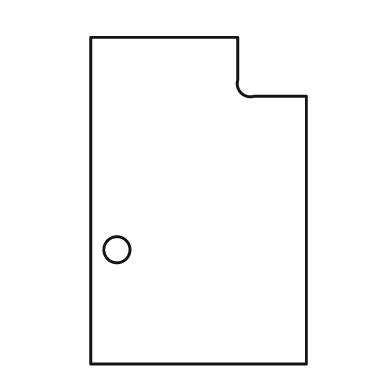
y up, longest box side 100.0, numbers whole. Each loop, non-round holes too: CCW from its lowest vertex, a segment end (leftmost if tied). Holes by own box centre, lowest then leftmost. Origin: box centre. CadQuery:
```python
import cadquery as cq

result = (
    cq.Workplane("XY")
    .moveTo(-33.0, -50.0)
    .lineTo(33.0, -50.0)
    .lineTo(33.0, 32.0)
    .lineTo(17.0, 32.0)
    .threePointArc((13.0, 33.0), (12.0, 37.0))
    .lineTo(12.0, 50.0)
    .lineTo(-33.0, 50.0)
    .close()
    .moveTo(-25.0, -15.0)
    .circle(4.0)
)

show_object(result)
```